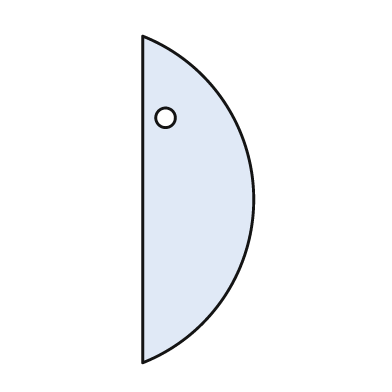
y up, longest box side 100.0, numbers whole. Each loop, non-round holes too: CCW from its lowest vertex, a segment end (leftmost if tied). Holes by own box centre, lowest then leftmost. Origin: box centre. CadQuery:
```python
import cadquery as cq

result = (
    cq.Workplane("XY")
    .moveTo(-17.0, -50.0)
    .threePointArc((17.0, 0.0), (-17.0, 50.0))
    .close()
    .moveTo(-10.0, 25.0)
    .circle(3.0)
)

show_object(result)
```